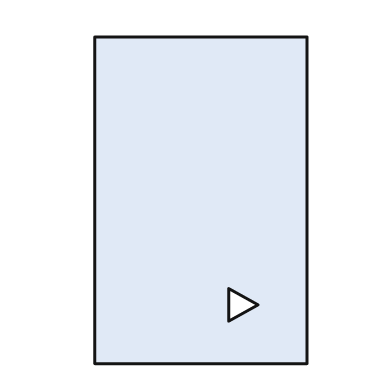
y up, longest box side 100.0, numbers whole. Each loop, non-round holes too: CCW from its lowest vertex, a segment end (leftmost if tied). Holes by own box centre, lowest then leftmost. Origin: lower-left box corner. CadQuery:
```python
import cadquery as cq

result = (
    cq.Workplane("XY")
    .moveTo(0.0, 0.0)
    .lineTo(65.0, 0.0)
    .lineTo(65.0, 100.0)
    .lineTo(0.0, 100.0)
    .close()
    .moveTo(41.0, 13.0)
    .lineTo(50.0, 18.0)
    .lineTo(41.0, 23.0)
    .close()
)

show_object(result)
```